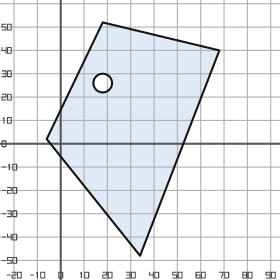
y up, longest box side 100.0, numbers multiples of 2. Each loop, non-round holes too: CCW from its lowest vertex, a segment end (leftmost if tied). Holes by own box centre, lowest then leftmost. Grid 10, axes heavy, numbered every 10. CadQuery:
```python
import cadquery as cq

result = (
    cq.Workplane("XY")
    .moveTo(34.0, -48.0)
    .lineTo(68.0, 40.0)
    .lineTo(18.0, 52.0)
    .lineTo(-6.0, 2.0)
    .close()
    .moveTo(18.0, 26.0)
    .circle(4.0)
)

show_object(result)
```